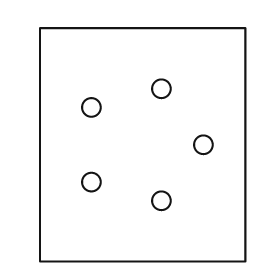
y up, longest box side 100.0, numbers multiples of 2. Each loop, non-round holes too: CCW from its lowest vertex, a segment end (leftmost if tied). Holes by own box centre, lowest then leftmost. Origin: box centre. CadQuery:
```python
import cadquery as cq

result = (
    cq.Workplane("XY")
    .moveTo(-44.0, -50.0)
    .lineTo(44.0, -50.0)
    .lineTo(44.0, 50.0)
    .lineTo(-44.0, 50.0)
    .close()
    .moveTo(8.0, -24.0)
    .circle(4.0)
    .moveTo(-22.0, -16.0)
    .circle(4.0)
    .moveTo(26.0, 0.0)
    .circle(4.0)
    .moveTo(-22.0, 16.0)
    .circle(4.0)
    .moveTo(8.0, 24.0)
    .circle(4.0)
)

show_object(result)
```